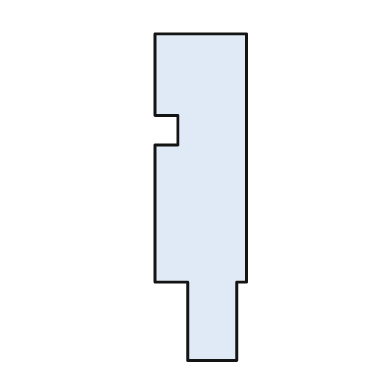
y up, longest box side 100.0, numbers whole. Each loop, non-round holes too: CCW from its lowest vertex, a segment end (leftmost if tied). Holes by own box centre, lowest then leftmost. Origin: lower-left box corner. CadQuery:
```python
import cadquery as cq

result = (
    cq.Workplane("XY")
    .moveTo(10.0, 0.0)
    .lineTo(25.0, 0.0)
    .lineTo(25.0, 24.0)
    .lineTo(28.0, 24.0)
    .lineTo(28.0, 100.0)
    .lineTo(0.0, 100.0)
    .lineTo(0.0, 75.0)
    .lineTo(7.0, 75.0)
    .lineTo(7.0, 66.0)
    .lineTo(0.0, 66.0)
    .lineTo(0.0, 24.0)
    .lineTo(10.0, 24.0)
    .close()
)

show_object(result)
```